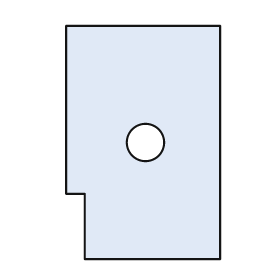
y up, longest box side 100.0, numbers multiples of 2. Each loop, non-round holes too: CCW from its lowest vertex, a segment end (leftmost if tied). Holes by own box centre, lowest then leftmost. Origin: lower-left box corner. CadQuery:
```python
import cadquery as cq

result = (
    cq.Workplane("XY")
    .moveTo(8.0, 0.0)
    .lineTo(66.0, 0.0)
    .lineTo(66.0, 100.0)
    .lineTo(0.0, 100.0)
    .lineTo(0.0, 28.0)
    .lineTo(8.0, 28.0)
    .close()
    .moveTo(34.0, 50.0)
    .circle(8.0)
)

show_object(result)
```